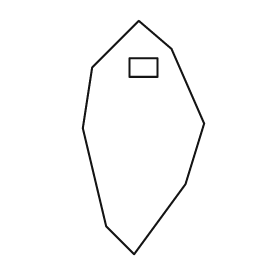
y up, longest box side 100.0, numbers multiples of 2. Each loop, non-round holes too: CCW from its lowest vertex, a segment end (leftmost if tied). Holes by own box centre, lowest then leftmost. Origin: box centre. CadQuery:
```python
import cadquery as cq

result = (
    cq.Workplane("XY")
    .moveTo(-4.0, -50.0)
    .lineTo(18.0, -20.0)
    .lineTo(26.0, 6.0)
    .lineTo(12.0, 38.0)
    .lineTo(-2.0, 50.0)
    .lineTo(-22.0, 30.0)
    .lineTo(-26.0, 4.0)
    .lineTo(-16.0, -38.0)
    .close()
    .moveTo(-6.0, 26.0)
    .lineTo(6.0, 26.0)
    .lineTo(6.0, 34.0)
    .lineTo(-6.0, 34.0)
    .close()
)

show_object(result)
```